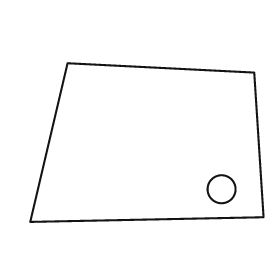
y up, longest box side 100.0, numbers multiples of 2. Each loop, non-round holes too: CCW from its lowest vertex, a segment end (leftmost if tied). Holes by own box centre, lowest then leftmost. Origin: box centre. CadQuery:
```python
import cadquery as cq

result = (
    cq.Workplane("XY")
    .moveTo(-50.0, -34.0)
    .lineTo(50.0, -32.0)
    .lineTo(46.0, 30.0)
    .lineTo(-34.0, 34.0)
    .close()
    .moveTo(32.0, -20.0)
    .circle(6.0)
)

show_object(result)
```